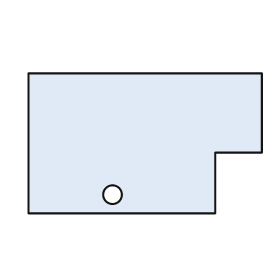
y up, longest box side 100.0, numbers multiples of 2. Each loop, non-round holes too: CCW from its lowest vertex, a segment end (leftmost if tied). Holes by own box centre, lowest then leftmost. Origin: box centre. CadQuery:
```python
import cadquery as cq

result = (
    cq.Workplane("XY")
    .moveTo(-50.0, -30.0)
    .lineTo(30.0, -30.0)
    .lineTo(30.0, -4.0)
    .lineTo(50.0, -4.0)
    .lineTo(50.0, 30.0)
    .lineTo(-50.0, 30.0)
    .close()
    .moveTo(-14.0, -22.0)
    .circle(4.0)
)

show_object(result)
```